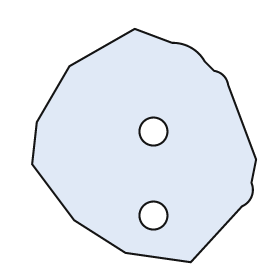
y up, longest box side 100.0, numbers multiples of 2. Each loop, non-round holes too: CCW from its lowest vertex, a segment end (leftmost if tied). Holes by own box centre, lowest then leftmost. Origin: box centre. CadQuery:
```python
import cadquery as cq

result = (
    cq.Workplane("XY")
    .moveTo(20.0, -50.0)
    .lineTo(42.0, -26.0)
    .threePointArc((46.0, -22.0), (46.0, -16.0))
    .lineTo(48.0, -6.0)
    .lineTo(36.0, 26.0)
    .threePointArc((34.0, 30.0), (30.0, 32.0))
    .lineTo(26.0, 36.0)
    .threePointArc((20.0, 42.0), (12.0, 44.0))
    .lineTo(-4.0, 50.0)
    .lineTo(-32.0, 34.0)
    .lineTo(-46.0, 10.0)
    .lineTo(-48.0, -8.0)
    .lineTo(-30.0, -32.0)
    .lineTo(-8.0, -46.0)
    .close()
    .moveTo(4.0, -30.0)
    .circle(6.0)
    .moveTo(4.0, 6.0)
    .circle(6.0)
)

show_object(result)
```